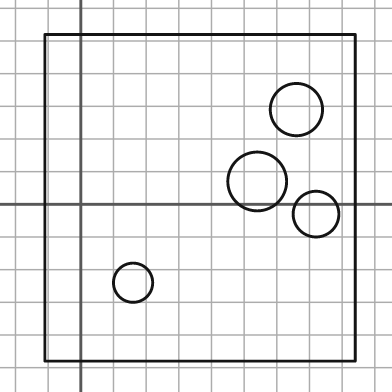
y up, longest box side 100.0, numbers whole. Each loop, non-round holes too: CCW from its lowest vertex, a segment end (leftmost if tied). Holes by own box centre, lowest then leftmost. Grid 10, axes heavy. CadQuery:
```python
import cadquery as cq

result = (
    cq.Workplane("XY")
    .moveTo(-11.0, -48.0)
    .lineTo(84.0, -48.0)
    .lineTo(84.0, 52.0)
    .lineTo(-11.0, 52.0)
    .close()
    .moveTo(16.0, -24.0)
    .circle(6.0)
    .moveTo(72.0, -3.0)
    .circle(7.0)
    .moveTo(54.0, 7.0)
    .circle(9.0)
    .moveTo(66.0, 29.0)
    .circle(8.0)
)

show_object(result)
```